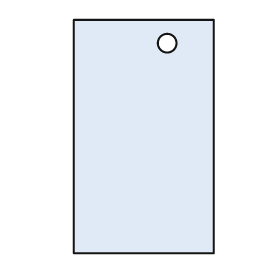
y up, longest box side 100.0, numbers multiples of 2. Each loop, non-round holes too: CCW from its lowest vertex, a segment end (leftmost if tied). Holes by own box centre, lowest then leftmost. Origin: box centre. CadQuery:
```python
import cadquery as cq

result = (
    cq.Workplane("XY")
    .moveTo(-30.0, -50.0)
    .lineTo(30.0, -50.0)
    .lineTo(30.0, 50.0)
    .lineTo(-30.0, 50.0)
    .close()
    .moveTo(10.0, 40.0)
    .circle(4.0)
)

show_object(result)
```